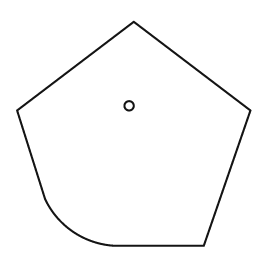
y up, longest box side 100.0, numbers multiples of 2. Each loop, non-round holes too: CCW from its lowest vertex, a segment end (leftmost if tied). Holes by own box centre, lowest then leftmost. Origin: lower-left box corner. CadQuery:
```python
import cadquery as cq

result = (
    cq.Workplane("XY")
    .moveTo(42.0, 0.0)
    .lineTo(80.0, 0.0)
    .lineTo(100.0, 58.0)
    .lineTo(50.0, 96.0)
    .lineTo(0.0, 58.0)
    .lineTo(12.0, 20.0)
    .threePointArc((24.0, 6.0), (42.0, 0.0))
    .close()
    .moveTo(48.0, 60.0)
    .circle(2.0)
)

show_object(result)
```